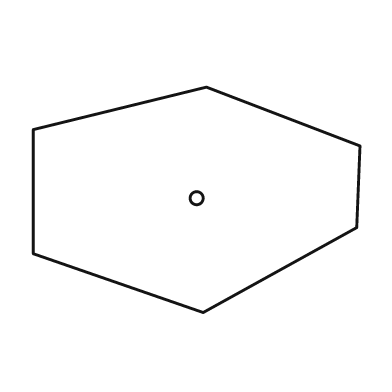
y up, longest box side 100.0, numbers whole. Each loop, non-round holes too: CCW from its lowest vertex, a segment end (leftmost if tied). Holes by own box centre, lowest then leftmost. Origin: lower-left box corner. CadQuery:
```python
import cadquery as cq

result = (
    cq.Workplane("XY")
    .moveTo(52.0, 0.0)
    .lineTo(99.0, 26.0)
    .lineTo(100.0, 51.0)
    .lineTo(53.0, 69.0)
    .lineTo(0.0, 56.0)
    .lineTo(0.0, 18.0)
    .close()
    .moveTo(50.0, 35.0)
    .circle(2.0)
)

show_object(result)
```